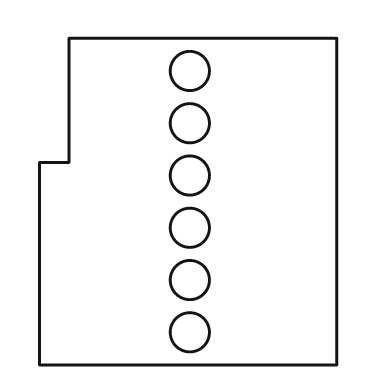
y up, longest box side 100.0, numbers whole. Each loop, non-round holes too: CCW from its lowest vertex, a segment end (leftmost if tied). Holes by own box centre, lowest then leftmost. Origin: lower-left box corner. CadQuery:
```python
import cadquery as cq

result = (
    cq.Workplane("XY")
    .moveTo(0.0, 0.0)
    .lineTo(91.0, 0.0)
    .lineTo(91.0, 100.0)
    .lineTo(9.0, 100.0)
    .lineTo(9.0, 62.0)
    .lineTo(0.0, 62.0)
    .close()
    .moveTo(46.0, 10.0)
    .circle(6.0)
    .moveTo(46.0, 26.0)
    .circle(6.0)
    .moveTo(46.0, 42.0)
    .circle(6.0)
    .moveTo(46.0, 58.0)
    .circle(6.0)
    .moveTo(46.0, 74.0)
    .circle(6.0)
    .moveTo(46.0, 90.0)
    .circle(6.0)
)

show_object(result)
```